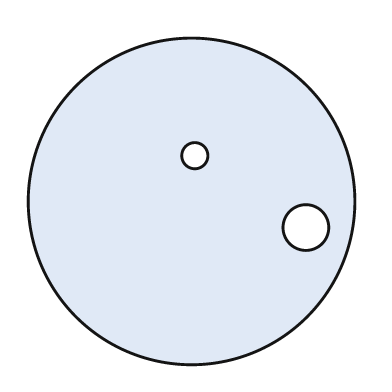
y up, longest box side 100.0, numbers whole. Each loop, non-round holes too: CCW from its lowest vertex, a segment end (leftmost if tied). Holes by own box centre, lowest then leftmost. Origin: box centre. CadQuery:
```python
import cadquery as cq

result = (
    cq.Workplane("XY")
    .moveTo(0.0, 0.0)
    .circle(50.0)
    .moveTo(35.0, -8.0)
    .circle(7.0)
    .moveTo(1.0, 14.0)
    .circle(4.0)
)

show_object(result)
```